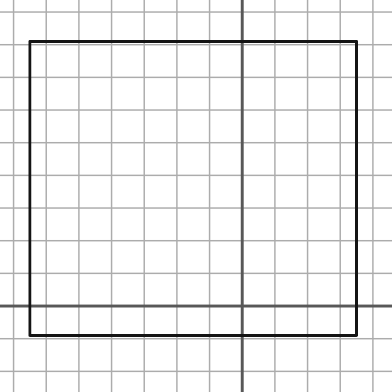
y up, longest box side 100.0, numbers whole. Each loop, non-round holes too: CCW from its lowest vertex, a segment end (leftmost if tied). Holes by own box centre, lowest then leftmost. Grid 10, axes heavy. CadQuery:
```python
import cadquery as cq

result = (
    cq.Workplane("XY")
    .moveTo(-65.0, -9.0)
    .lineTo(35.0, -9.0)
    .lineTo(35.0, 81.0)
    .lineTo(-65.0, 81.0)
    .close()
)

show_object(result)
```